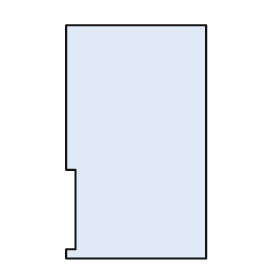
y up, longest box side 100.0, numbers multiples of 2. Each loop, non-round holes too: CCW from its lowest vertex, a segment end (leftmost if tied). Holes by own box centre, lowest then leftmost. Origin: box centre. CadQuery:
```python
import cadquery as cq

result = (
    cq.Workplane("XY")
    .moveTo(-30.0, -50.0)
    .lineTo(30.0, -50.0)
    .lineTo(30.0, 50.0)
    .lineTo(-30.0, 50.0)
    .lineTo(-30.0, -12.0)
    .lineTo(-26.0, -12.0)
    .lineTo(-26.0, -46.0)
    .lineTo(-30.0, -46.0)
    .close()
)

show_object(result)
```